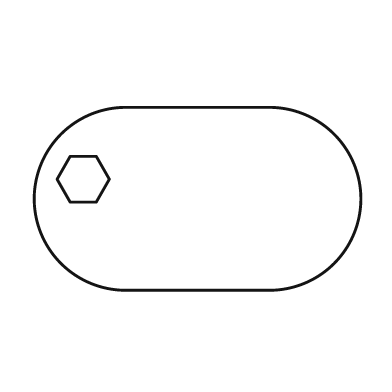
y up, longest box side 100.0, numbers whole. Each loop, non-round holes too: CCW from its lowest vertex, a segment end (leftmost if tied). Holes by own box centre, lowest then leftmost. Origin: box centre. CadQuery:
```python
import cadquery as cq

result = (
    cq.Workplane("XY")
    .moveTo(-22.0, -28.0)
    .lineTo(22.0, -28.0)
    .threePointArc((50.0, 0.0), (22.0, 28.0))
    .lineTo(-22.0, 28.0)
    .threePointArc((-50.0, 0.0), (-22.0, -28.0))
    .close()
    .moveTo(-39.0, -1.0)
    .lineTo(-31.0, -1.0)
    .lineTo(-27.0, 6.0)
    .lineTo(-31.0, 13.0)
    .lineTo(-39.0, 13.0)
    .lineTo(-43.0, 6.0)
    .close()
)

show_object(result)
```